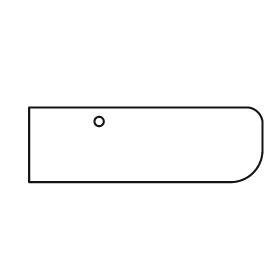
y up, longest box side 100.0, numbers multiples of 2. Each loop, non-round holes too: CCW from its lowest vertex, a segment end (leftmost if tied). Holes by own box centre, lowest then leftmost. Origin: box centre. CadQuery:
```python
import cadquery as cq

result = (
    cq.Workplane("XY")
    .moveTo(-50.0, -16.0)
    .lineTo(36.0, -16.0)
    .threePointArc((46.0, -12.0), (50.0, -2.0))
    .lineTo(50.0, 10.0)
    .threePointArc((48.0, 14.0), (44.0, 16.0))
    .lineTo(-50.0, 16.0)
    .close()
    .moveTo(-20.0, 10.0)
    .circle(2.0)
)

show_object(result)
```